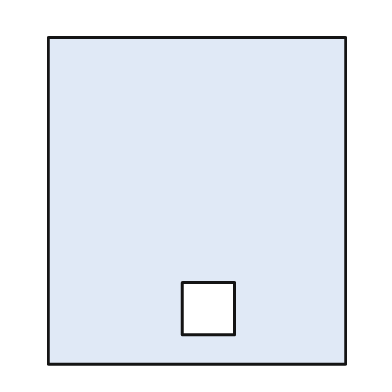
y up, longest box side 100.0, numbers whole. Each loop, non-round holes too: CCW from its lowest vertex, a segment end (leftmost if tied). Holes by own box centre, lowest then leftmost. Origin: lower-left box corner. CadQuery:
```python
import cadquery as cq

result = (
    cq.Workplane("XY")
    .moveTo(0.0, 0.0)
    .lineTo(91.0, 0.0)
    .lineTo(91.0, 100.0)
    .lineTo(0.0, 100.0)
    .close()
    .moveTo(41.0, 9.0)
    .lineTo(57.0, 9.0)
    .lineTo(57.0, 25.0)
    .lineTo(41.0, 25.0)
    .close()
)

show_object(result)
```